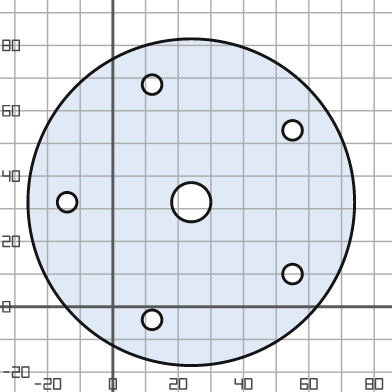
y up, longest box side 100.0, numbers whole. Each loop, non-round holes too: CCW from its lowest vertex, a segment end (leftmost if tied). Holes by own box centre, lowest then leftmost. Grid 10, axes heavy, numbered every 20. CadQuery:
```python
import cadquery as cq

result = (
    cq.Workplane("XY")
    .moveTo(24.0, 32.0)
    .circle(50.0)
    .moveTo(12.0, -4.0)
    .circle(3.0)
    .moveTo(55.0, 10.0)
    .circle(3.0)
    .moveTo(-14.0, 32.0)
    .circle(3.0)
    .moveTo(24.0, 32.0)
    .circle(6.0)
    .moveTo(55.0, 54.0)
    .circle(3.0)
    .moveTo(12.0, 68.0)
    .circle(3.0)
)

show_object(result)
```